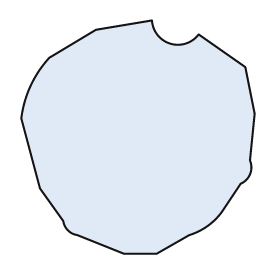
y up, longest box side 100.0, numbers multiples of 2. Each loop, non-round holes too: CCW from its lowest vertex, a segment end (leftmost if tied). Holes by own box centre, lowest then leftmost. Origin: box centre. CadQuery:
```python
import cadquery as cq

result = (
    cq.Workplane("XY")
    .moveTo(-6.0, -50.0)
    .lineTo(8.0, -50.0)
    .lineTo(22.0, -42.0)
    .threePointArc((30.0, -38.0), (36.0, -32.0))
    .lineTo(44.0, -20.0)
    .threePointArc((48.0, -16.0), (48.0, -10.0))
    .lineTo(50.0, 10.0)
    .lineTo(46.0, 30.0)
    .lineTo(26.0, 44.0)
    .threePointArc((14.0, 40.0), (6.0, 50.0))
    .lineTo(-18.0, 46.0)
    .lineTo(-38.0, 34.0)
    .threePointArc((-46.0, 22.0), (-50.0, 8.0))
    .lineTo(-42.0, -22.0)
    .lineTo(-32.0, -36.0)
    .threePointArc((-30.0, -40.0), (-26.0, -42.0))
    .close()
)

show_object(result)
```